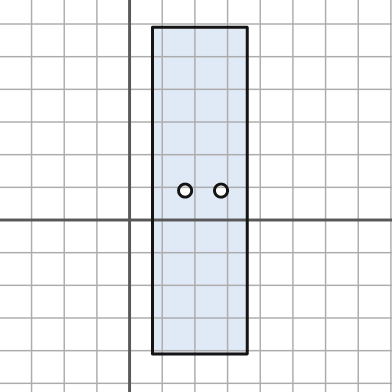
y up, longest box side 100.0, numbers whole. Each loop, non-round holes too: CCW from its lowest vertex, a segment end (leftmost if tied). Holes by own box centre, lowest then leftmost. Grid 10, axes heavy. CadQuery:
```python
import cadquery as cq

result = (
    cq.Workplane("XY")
    .moveTo(7.0, -41.0)
    .lineTo(36.0, -41.0)
    .lineTo(36.0, 59.0)
    .lineTo(7.0, 59.0)
    .close()
    .moveTo(17.0, 9.0)
    .circle(2.0)
    .moveTo(28.0, 9.0)
    .circle(2.0)
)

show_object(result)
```